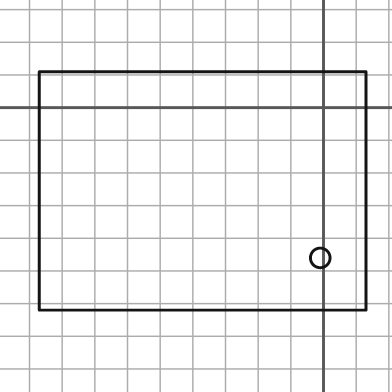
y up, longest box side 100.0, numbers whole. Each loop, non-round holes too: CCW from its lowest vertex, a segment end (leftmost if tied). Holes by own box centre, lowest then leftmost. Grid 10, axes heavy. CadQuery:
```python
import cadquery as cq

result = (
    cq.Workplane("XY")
    .moveTo(-87.0, -62.0)
    .lineTo(13.0, -62.0)
    .lineTo(13.0, 11.0)
    .lineTo(-87.0, 11.0)
    .close()
    .moveTo(-1.0, -46.0)
    .circle(3.0)
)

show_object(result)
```